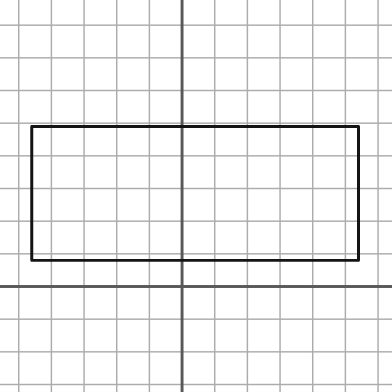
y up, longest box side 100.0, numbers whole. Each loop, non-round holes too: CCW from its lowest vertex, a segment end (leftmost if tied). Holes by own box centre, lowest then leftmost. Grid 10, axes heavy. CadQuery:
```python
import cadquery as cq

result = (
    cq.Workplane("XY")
    .moveTo(-46.0, 8.0)
    .lineTo(54.0, 8.0)
    .lineTo(54.0, 49.0)
    .lineTo(-46.0, 49.0)
    .close()
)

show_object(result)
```